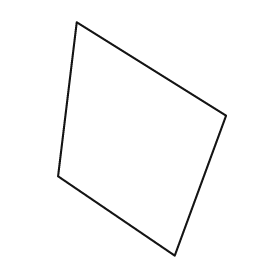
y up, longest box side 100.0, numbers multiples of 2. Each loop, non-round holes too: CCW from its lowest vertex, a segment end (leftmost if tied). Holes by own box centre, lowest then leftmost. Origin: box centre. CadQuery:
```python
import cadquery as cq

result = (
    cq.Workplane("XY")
    .moveTo(14.0, -50.0)
    .lineTo(36.0, 10.0)
    .lineTo(-28.0, 50.0)
    .lineTo(-36.0, -16.0)
    .close()
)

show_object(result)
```